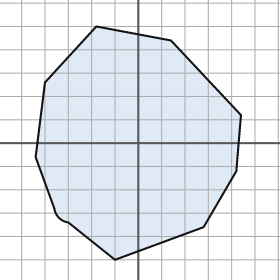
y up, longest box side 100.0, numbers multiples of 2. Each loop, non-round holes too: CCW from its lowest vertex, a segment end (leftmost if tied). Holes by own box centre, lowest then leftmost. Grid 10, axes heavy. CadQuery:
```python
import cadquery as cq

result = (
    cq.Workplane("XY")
    .moveTo(-10.0, -50.0)
    .lineTo(28.0, -36.0)
    .lineTo(42.0, -12.0)
    .lineTo(44.0, 12.0)
    .lineTo(14.0, 44.0)
    .lineTo(-18.0, 50.0)
    .lineTo(-40.0, 26.0)
    .lineTo(-44.0, -6.0)
    .lineTo(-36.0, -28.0)
    .threePointArc((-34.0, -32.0), (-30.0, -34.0))
    .close()
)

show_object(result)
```